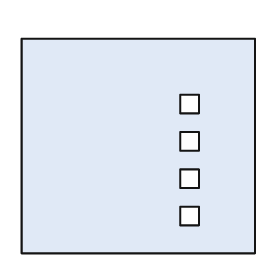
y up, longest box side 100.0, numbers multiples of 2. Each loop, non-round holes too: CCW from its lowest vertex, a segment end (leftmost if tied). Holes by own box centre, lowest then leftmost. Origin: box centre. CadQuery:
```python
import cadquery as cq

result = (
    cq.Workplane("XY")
    .moveTo(-50.0, -46.0)
    .lineTo(50.0, -46.0)
    .lineTo(50.0, 46.0)
    .lineTo(-50.0, 46.0)
    .close()
    .moveTo(18.0, -34.0)
    .lineTo(26.0, -34.0)
    .lineTo(26.0, -26.0)
    .lineTo(18.0, -26.0)
    .close()
    .moveTo(18.0, -18.0)
    .lineTo(26.0, -18.0)
    .lineTo(26.0, -10.0)
    .lineTo(18.0, -10.0)
    .close()
    .moveTo(18.0, -2.0)
    .lineTo(26.0, -2.0)
    .lineTo(26.0, 6.0)
    .lineTo(18.0, 6.0)
    .close()
    .moveTo(18.0, 14.0)
    .lineTo(26.0, 14.0)
    .lineTo(26.0, 22.0)
    .lineTo(18.0, 22.0)
    .close()
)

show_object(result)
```